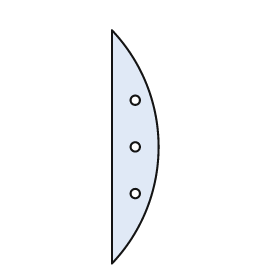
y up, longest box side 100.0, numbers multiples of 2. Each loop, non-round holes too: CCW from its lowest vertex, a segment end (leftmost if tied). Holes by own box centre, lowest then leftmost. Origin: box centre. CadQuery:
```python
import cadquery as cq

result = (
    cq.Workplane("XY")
    .moveTo(-10.0, -50.0)
    .threePointArc((10.0, 0.0), (-10.0, 50.0))
    .close()
    .moveTo(0.0, -20.0)
    .circle(2.0)
    .moveTo(0.0, 0.0)
    .circle(2.0)
    .moveTo(0.0, 20.0)
    .circle(2.0)
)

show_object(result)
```